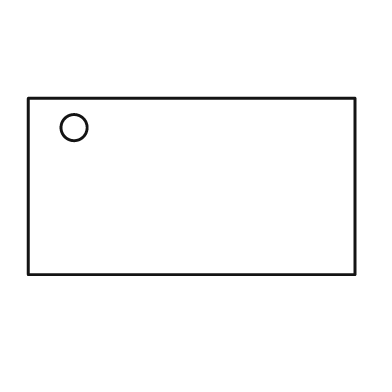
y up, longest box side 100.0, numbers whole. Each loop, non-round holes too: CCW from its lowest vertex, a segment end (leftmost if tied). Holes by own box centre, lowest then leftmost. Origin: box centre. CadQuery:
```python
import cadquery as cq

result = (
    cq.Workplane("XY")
    .moveTo(-50.0, -27.0)
    .lineTo(50.0, -27.0)
    .lineTo(50.0, 27.0)
    .lineTo(-50.0, 27.0)
    .close()
    .moveTo(-36.0, 18.0)
    .circle(4.0)
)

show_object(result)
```